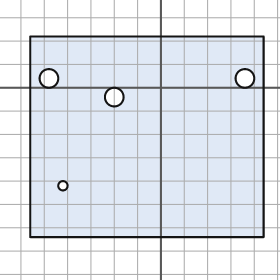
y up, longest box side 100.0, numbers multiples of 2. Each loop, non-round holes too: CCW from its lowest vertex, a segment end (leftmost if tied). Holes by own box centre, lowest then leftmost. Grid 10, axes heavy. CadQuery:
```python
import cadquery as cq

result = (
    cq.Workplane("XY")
    .moveTo(-56.0, -64.0)
    .lineTo(44.0, -64.0)
    .lineTo(44.0, 22.0)
    .lineTo(-56.0, 22.0)
    .close()
    .moveTo(-42.0, -42.0)
    .circle(2.0)
    .moveTo(-20.0, -4.0)
    .circle(4.0)
    .moveTo(-48.0, 4.0)
    .circle(4.0)
    .moveTo(36.0, 4.0)
    .circle(4.0)
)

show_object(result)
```